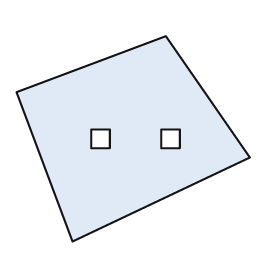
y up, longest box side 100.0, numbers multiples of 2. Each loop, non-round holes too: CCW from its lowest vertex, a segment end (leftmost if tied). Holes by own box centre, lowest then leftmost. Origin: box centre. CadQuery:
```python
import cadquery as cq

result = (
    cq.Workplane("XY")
    .moveTo(-26.0, -44.0)
    .lineTo(50.0, -8.0)
    .lineTo(14.0, 44.0)
    .lineTo(-50.0, 20.0)
    .close()
    .moveTo(-18.0, -4.0)
    .lineTo(-10.0, -4.0)
    .lineTo(-10.0, 4.0)
    .lineTo(-18.0, 4.0)
    .close()
    .moveTo(12.0, -4.0)
    .lineTo(20.0, -4.0)
    .lineTo(20.0, 4.0)
    .lineTo(12.0, 4.0)
    .close()
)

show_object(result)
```